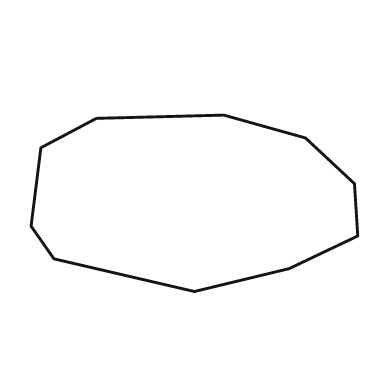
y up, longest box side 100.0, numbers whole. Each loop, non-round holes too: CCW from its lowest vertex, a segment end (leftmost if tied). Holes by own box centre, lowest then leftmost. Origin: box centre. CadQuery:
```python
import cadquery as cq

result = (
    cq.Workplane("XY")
    .moveTo(0.0, -27.0)
    .lineTo(29.0, -20.0)
    .lineTo(50.0, -10.0)
    .lineTo(49.0, 6.0)
    .lineTo(34.0, 20.0)
    .lineTo(9.0, 27.0)
    .lineTo(-30.0, 26.0)
    .lineTo(-47.0, 17.0)
    .lineTo(-50.0, -7.0)
    .lineTo(-43.0, -17.0)
    .close()
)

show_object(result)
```